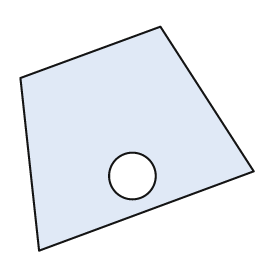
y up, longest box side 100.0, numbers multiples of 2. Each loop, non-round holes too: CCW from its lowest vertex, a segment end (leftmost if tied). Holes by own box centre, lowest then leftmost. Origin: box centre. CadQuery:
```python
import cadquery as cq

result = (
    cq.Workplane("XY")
    .moveTo(-42.0, -48.0)
    .lineTo(50.0, -14.0)
    .lineTo(10.0, 48.0)
    .lineTo(-50.0, 26.0)
    .close()
    .moveTo(-2.0, -16.0)
    .circle(10.0)
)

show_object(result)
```